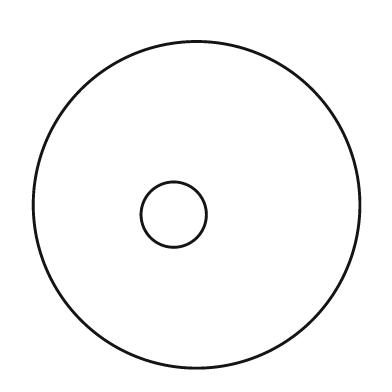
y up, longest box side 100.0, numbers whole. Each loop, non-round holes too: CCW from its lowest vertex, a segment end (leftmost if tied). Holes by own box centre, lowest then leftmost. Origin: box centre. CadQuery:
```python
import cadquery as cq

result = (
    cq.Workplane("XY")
    .moveTo(0.0, 0.0)
    .circle(50.0)
    .moveTo(-7.0, -3.0)
    .circle(10.0)
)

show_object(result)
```